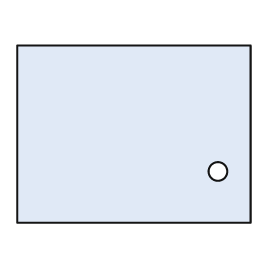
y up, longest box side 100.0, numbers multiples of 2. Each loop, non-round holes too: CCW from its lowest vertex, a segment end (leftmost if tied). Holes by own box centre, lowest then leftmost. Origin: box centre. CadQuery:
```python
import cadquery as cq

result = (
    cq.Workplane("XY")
    .moveTo(-50.0, -38.0)
    .lineTo(50.0, -38.0)
    .lineTo(50.0, 38.0)
    .lineTo(-50.0, 38.0)
    .close()
    .moveTo(36.0, -16.0)
    .circle(4.0)
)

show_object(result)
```